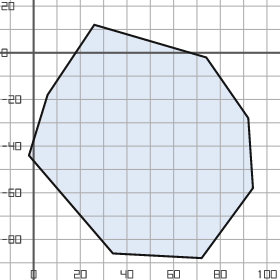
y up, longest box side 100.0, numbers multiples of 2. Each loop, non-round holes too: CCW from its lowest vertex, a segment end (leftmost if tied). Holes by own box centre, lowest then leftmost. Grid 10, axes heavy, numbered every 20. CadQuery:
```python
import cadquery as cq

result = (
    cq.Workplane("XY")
    .moveTo(72.0, -88.0)
    .lineTo(94.0, -58.0)
    .lineTo(92.0, -28.0)
    .lineTo(74.0, -2.0)
    .lineTo(26.0, 12.0)
    .lineTo(6.0, -18.0)
    .lineTo(-2.0, -44.0)
    .lineTo(34.0, -86.0)
    .close()
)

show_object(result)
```